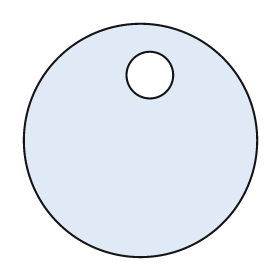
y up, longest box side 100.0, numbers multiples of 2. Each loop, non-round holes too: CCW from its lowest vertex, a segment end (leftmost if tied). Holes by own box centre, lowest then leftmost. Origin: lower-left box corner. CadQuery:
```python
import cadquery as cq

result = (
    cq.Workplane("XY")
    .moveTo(50.0, 50.0)
    .circle(50.0)
    .moveTo(54.0, 78.0)
    .circle(10.0)
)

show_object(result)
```